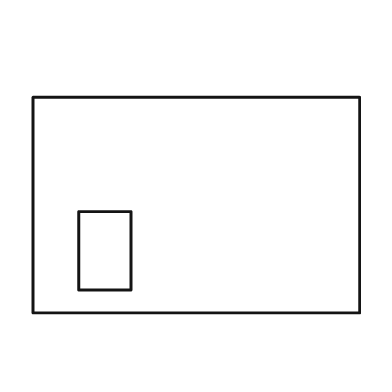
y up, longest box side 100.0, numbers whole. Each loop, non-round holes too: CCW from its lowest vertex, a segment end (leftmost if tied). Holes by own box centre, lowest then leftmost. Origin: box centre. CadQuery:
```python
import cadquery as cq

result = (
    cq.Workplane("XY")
    .moveTo(-50.0, -33.0)
    .lineTo(50.0, -33.0)
    .lineTo(50.0, 33.0)
    .lineTo(-50.0, 33.0)
    .close()
    .moveTo(-36.0, -26.0)
    .lineTo(-20.0, -26.0)
    .lineTo(-20.0, -2.0)
    .lineTo(-36.0, -2.0)
    .close()
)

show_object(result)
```